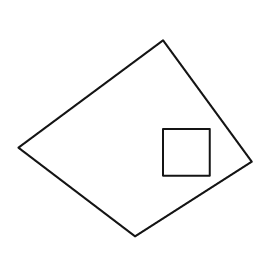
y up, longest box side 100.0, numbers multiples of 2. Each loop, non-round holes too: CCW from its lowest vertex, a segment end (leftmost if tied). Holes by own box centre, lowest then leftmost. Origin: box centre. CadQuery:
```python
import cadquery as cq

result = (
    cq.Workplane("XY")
    .moveTo(0.0, -42.0)
    .lineTo(50.0, -10.0)
    .lineTo(12.0, 42.0)
    .lineTo(-50.0, -4.0)
    .close()
    .moveTo(12.0, -16.0)
    .lineTo(32.0, -16.0)
    .lineTo(32.0, 4.0)
    .lineTo(12.0, 4.0)
    .close()
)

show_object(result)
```